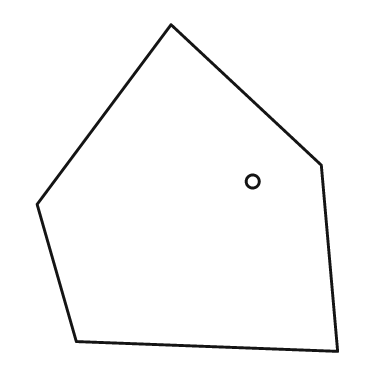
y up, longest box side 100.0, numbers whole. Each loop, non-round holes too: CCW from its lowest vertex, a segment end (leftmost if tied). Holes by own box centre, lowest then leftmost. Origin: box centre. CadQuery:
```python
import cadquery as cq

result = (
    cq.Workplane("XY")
    .moveTo(46.0, -50.0)
    .lineTo(41.0, 7.0)
    .lineTo(-5.0, 50.0)
    .lineTo(-46.0, -5.0)
    .lineTo(-34.0, -47.0)
    .close()
    .moveTo(20.0, 2.0)
    .circle(2.0)
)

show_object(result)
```